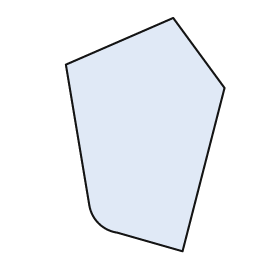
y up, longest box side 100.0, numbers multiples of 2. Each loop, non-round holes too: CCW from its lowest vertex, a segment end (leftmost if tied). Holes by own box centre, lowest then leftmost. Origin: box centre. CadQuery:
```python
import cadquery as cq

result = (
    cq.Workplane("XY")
    .moveTo(16.0, -50.0)
    .lineTo(34.0, 20.0)
    .lineTo(12.0, 50.0)
    .lineTo(-34.0, 30.0)
    .lineTo(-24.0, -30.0)
    .threePointArc((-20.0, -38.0), (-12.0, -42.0))
    .close()
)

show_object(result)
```